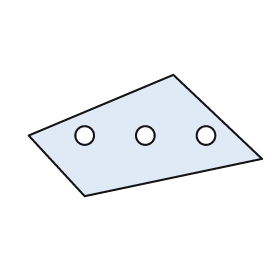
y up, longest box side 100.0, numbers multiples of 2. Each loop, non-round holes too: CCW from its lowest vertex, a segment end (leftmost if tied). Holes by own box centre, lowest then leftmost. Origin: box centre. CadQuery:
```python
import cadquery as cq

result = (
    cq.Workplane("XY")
    .moveTo(-26.0, -26.0)
    .lineTo(50.0, -10.0)
    .lineTo(12.0, 26.0)
    .lineTo(-50.0, 0.0)
    .close()
    .moveTo(-26.0, 0.0)
    .circle(4.0)
    .moveTo(0.0, 0.0)
    .circle(4.0)
    .moveTo(26.0, 0.0)
    .circle(4.0)
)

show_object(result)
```